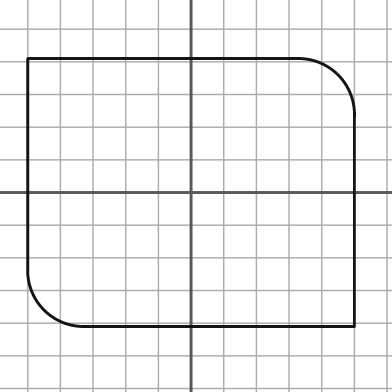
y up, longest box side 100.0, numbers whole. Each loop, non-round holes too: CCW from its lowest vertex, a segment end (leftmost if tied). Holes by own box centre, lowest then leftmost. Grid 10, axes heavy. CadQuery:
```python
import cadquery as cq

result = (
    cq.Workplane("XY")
    .moveTo(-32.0, -41.0)
    .lineTo(50.0, -41.0)
    .lineTo(50.0, 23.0)
    .threePointArc((45.0, 36.0), (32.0, 41.0))
    .lineTo(-50.0, 41.0)
    .lineTo(-50.0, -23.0)
    .threePointArc((-45.0, -36.0), (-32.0, -41.0))
    .close()
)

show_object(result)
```